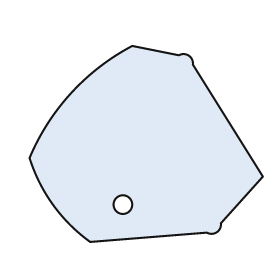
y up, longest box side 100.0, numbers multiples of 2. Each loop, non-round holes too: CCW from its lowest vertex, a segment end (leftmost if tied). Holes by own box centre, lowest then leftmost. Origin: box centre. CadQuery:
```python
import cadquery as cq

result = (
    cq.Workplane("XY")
    .moveTo(-24.0, -42.0)
    .lineTo(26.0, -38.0)
    .threePointArc((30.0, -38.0), (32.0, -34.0))
    .lineTo(50.0, -14.0)
    .lineTo(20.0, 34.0)
    .threePointArc((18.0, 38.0), (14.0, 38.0))
    .lineTo(-6.0, 42.0)
    .threePointArc((-32.0, 22.0), (-50.0, -6.0))
    .threePointArc((-40.0, -26.0), (-24.0, -42.0))
    .close()
    .moveTo(-10.0, -26.0)
    .circle(4.0)
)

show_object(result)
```